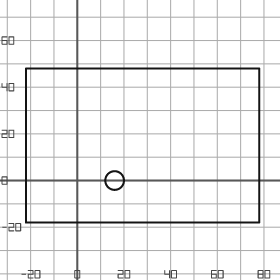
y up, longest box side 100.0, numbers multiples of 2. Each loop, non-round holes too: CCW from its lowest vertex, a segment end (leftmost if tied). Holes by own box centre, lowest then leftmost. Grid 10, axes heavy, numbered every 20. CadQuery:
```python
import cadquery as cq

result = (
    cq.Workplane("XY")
    .moveTo(-22.0, -18.0)
    .lineTo(78.0, -18.0)
    .lineTo(78.0, 48.0)
    .lineTo(-22.0, 48.0)
    .close()
    .moveTo(16.0, 0.0)
    .circle(4.0)
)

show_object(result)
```